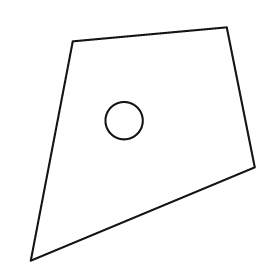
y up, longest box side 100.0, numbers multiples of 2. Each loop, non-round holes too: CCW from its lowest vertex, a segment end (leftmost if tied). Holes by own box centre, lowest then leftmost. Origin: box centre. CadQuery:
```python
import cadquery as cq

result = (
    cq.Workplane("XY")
    .moveTo(-48.0, -50.0)
    .lineTo(48.0, -10.0)
    .lineTo(36.0, 50.0)
    .lineTo(-30.0, 44.0)
    .close()
    .moveTo(-8.0, 10.0)
    .circle(8.0)
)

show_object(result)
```